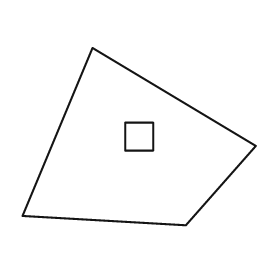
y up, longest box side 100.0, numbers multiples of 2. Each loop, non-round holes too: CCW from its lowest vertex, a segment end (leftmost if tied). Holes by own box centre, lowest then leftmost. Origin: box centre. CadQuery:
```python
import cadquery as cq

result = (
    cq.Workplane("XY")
    .moveTo(20.0, -38.0)
    .lineTo(50.0, -4.0)
    .lineTo(-20.0, 38.0)
    .lineTo(-50.0, -34.0)
    .close()
    .moveTo(-6.0, -6.0)
    .lineTo(6.0, -6.0)
    .lineTo(6.0, 6.0)
    .lineTo(-6.0, 6.0)
    .close()
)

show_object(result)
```